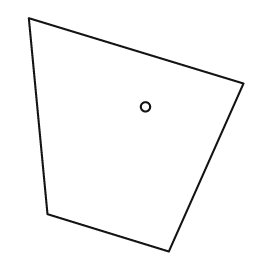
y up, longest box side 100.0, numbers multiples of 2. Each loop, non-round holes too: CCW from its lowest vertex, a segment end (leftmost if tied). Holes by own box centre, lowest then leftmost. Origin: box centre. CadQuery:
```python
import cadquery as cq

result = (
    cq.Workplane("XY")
    .moveTo(14.0, -50.0)
    .lineTo(46.0, 22.0)
    .lineTo(-46.0, 50.0)
    .lineTo(-38.0, -34.0)
    .close()
    .moveTo(4.0, 12.0)
    .circle(2.0)
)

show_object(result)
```